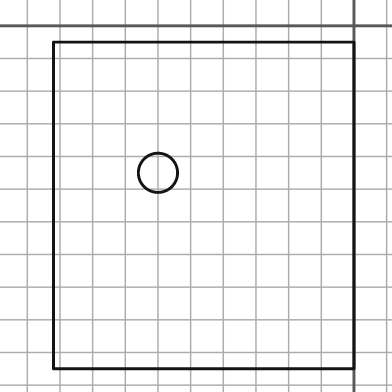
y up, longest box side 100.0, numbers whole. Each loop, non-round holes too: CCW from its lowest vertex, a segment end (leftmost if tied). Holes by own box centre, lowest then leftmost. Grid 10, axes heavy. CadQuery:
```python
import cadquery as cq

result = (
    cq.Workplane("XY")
    .moveTo(-92.0, -105.0)
    .lineTo(0.0, -105.0)
    .lineTo(0.0, -5.0)
    .lineTo(-92.0, -5.0)
    .close()
    .moveTo(-60.0, -45.0)
    .circle(6.0)
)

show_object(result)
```